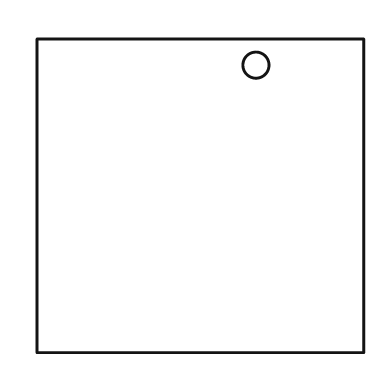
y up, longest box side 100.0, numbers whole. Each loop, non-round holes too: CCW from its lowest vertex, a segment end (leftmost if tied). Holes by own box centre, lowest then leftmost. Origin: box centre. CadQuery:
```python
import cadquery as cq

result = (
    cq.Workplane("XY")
    .moveTo(-50.0, -48.0)
    .lineTo(50.0, -48.0)
    .lineTo(50.0, 48.0)
    .lineTo(-50.0, 48.0)
    .close()
    .moveTo(17.0, 40.0)
    .circle(4.0)
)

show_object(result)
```